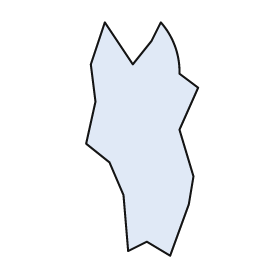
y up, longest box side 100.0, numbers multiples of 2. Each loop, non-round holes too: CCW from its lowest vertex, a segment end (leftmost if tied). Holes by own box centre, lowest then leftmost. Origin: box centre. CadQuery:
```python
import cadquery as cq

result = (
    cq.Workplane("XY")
    .moveTo(12.0, -50.0)
    .lineTo(20.0, -28.0)
    .lineTo(22.0, -16.0)
    .lineTo(16.0, 4.0)
    .lineTo(24.0, 22.0)
    .lineTo(16.0, 28.0)
    .threePointArc((14.0, 40.0), (8.0, 50.0))
    .lineTo(4.0, 42.0)
    .lineTo(-4.0, 32.0)
    .lineTo(-16.0, 50.0)
    .lineTo(-22.0, 32.0)
    .lineTo(-20.0, 16.0)
    .lineTo(-24.0, -2.0)
    .lineTo(-14.0, -10.0)
    .lineTo(-8.0, -24.0)
    .lineTo(-6.0, -48.0)
    .lineTo(2.0, -44.0)
    .close()
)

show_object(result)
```